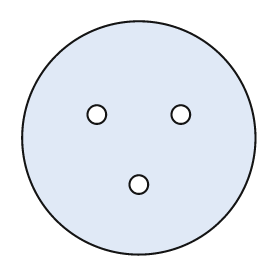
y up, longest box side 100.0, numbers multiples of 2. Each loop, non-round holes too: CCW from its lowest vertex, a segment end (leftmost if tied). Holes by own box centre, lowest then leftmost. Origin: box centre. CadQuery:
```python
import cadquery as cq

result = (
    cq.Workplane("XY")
    .moveTo(0.0, 0.0)
    .circle(50.0)
    .moveTo(0.0, -20.0)
    .circle(4.0)
    .moveTo(-18.0, 10.0)
    .circle(4.0)
    .moveTo(18.0, 10.0)
    .circle(4.0)
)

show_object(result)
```